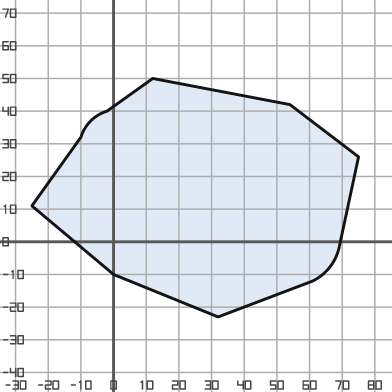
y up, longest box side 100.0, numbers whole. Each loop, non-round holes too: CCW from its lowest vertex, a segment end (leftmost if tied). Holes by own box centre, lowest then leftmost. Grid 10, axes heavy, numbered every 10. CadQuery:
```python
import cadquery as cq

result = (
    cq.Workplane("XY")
    .moveTo(32.0, -23.0)
    .lineTo(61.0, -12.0)
    .threePointArc((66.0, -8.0), (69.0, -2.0))
    .lineTo(75.0, 26.0)
    .lineTo(54.0, 42.0)
    .lineTo(12.0, 50.0)
    .lineTo(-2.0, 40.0)
    .threePointArc((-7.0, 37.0), (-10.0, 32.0))
    .lineTo(-25.0, 11.0)
    .lineTo(0.0, -10.0)
    .close()
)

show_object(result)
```